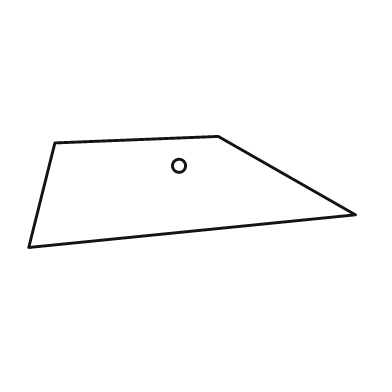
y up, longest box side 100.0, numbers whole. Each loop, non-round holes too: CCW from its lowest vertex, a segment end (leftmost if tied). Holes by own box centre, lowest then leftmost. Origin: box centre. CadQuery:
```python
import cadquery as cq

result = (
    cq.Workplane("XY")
    .moveTo(-50.0, -17.0)
    .lineTo(50.0, -7.0)
    .lineTo(8.0, 17.0)
    .lineTo(-42.0, 15.0)
    .close()
    .moveTo(-4.0, 8.0)
    .circle(2.0)
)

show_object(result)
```